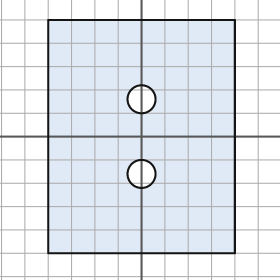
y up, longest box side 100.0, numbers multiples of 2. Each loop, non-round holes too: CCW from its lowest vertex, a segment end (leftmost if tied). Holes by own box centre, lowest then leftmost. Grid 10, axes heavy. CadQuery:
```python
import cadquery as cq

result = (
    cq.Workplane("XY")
    .moveTo(-40.0, -50.0)
    .lineTo(40.0, -50.0)
    .lineTo(40.0, 50.0)
    .lineTo(-40.0, 50.0)
    .close()
    .moveTo(0.0, -16.0)
    .circle(6.0)
    .moveTo(0.0, 16.0)
    .circle(6.0)
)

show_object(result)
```